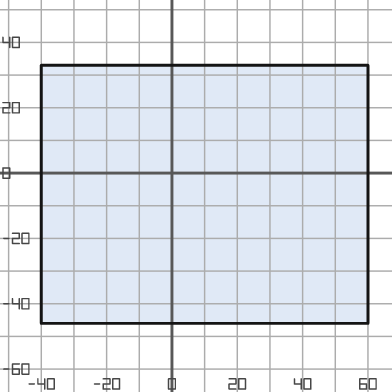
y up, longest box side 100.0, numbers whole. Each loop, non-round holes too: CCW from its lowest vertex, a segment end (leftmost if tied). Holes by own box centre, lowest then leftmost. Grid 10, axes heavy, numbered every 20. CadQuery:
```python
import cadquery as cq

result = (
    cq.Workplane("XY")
    .moveTo(-40.0, -46.0)
    .lineTo(60.0, -46.0)
    .lineTo(60.0, 33.0)
    .lineTo(-40.0, 33.0)
    .close()
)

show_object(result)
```